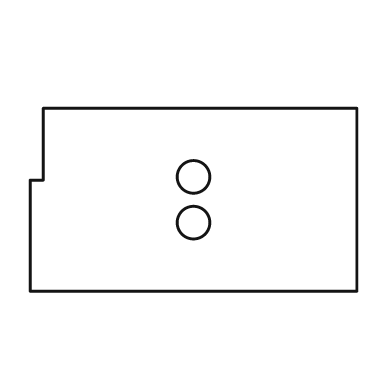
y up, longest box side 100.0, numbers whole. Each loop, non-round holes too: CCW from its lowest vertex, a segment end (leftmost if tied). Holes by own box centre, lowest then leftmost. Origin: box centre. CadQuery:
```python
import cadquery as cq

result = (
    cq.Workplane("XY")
    .moveTo(-50.0, -28.0)
    .lineTo(50.0, -28.0)
    .lineTo(50.0, 28.0)
    .lineTo(-46.0, 28.0)
    .lineTo(-46.0, 6.0)
    .lineTo(-50.0, 6.0)
    .close()
    .moveTo(0.0, -7.0)
    .circle(5.0)
    .moveTo(0.0, 7.0)
    .circle(5.0)
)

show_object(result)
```